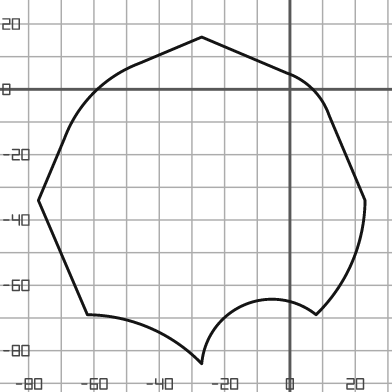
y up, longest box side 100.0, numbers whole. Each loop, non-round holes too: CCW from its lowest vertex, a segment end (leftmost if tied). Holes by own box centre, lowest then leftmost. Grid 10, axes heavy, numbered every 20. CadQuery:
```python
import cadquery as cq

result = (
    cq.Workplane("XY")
    .moveTo(-27.0, -84.0)
    .threePointArc((-14.0, -66.0), (8.0, -69.0))
    .threePointArc((19.0, -53.0), (23.0, -34.0))
    .lineTo(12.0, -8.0)
    .threePointArc((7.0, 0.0), (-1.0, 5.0))
    .lineTo(-27.0, 16.0)
    .lineTo(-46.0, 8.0)
    .threePointArc((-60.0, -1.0), (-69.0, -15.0))
    .lineTo(-77.0, -34.0)
    .lineTo(-62.0, -69.0)
    .threePointArc((-43.0, -73.0), (-27.0, -84.0))
    .close()
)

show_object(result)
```